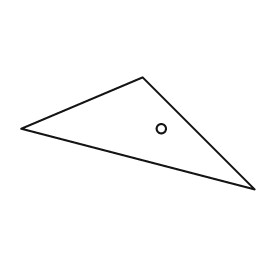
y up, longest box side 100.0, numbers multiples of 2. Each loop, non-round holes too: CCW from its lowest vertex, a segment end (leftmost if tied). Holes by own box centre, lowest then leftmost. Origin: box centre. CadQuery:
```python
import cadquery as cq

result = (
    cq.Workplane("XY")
    .moveTo(50.0, -24.0)
    .lineTo(2.0, 24.0)
    .lineTo(-50.0, 2.0)
    .close()
    .moveTo(10.0, 2.0)
    .circle(2.0)
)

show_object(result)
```